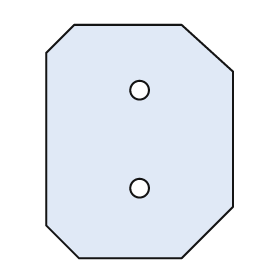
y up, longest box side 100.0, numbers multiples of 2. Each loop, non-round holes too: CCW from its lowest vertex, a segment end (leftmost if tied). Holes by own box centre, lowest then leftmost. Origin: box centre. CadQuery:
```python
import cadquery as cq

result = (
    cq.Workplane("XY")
    .moveTo(-26.0, -50.0)
    .lineTo(18.0, -50.0)
    .lineTo(40.0, -28.0)
    .lineTo(40.0, 30.0)
    .lineTo(18.0, 50.0)
    .lineTo(-28.0, 50.0)
    .lineTo(-40.0, 38.0)
    .lineTo(-40.0, -36.0)
    .close()
    .moveTo(0.0, -20.0)
    .circle(4.0)
    .moveTo(0.0, 22.0)
    .circle(4.0)
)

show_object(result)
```